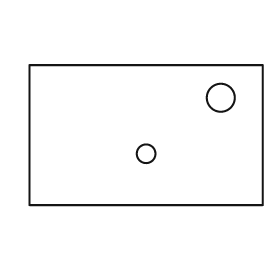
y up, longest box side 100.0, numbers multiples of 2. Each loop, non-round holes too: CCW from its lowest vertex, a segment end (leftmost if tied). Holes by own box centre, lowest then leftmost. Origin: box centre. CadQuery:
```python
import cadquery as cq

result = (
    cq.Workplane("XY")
    .moveTo(-50.0, -30.0)
    .lineTo(50.0, -30.0)
    .lineTo(50.0, 30.0)
    .lineTo(-50.0, 30.0)
    .close()
    .moveTo(0.0, -8.0)
    .circle(4.0)
    .moveTo(32.0, 16.0)
    .circle(6.0)
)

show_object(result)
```